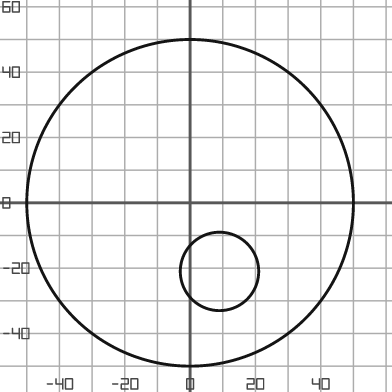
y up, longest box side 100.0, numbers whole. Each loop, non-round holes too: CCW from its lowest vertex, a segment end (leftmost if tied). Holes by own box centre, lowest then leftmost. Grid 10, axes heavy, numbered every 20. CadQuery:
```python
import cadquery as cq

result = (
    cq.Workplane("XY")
    .moveTo(0.0, 0.0)
    .circle(50.0)
    .moveTo(9.0, -21.0)
    .circle(12.0)
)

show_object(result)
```